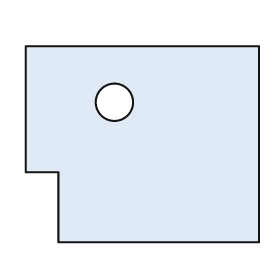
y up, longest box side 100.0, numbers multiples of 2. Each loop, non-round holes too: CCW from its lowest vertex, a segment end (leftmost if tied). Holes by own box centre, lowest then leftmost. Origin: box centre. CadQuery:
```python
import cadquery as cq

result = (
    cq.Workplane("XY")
    .moveTo(-36.0, -42.0)
    .lineTo(50.0, -42.0)
    .lineTo(50.0, 42.0)
    .lineTo(-50.0, 42.0)
    .lineTo(-50.0, -12.0)
    .lineTo(-36.0, -12.0)
    .close()
    .moveTo(-12.0, 18.0)
    .circle(8.0)
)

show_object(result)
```